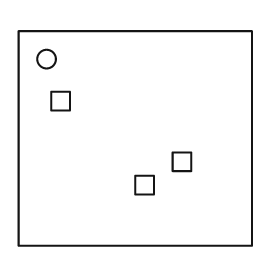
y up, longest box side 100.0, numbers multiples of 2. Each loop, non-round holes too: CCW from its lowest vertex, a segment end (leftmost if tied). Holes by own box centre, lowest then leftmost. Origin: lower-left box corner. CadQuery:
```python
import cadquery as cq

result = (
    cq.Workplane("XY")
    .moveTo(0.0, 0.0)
    .lineTo(100.0, 0.0)
    .lineTo(100.0, 92.0)
    .lineTo(0.0, 92.0)
    .close()
    .moveTo(50.0, 22.0)
    .lineTo(58.0, 22.0)
    .lineTo(58.0, 30.0)
    .lineTo(50.0, 30.0)
    .close()
    .moveTo(66.0, 32.0)
    .lineTo(74.0, 32.0)
    .lineTo(74.0, 40.0)
    .lineTo(66.0, 40.0)
    .close()
    .moveTo(14.0, 58.0)
    .lineTo(22.0, 58.0)
    .lineTo(22.0, 66.0)
    .lineTo(14.0, 66.0)
    .close()
    .moveTo(12.0, 80.0)
    .circle(4.0)
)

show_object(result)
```